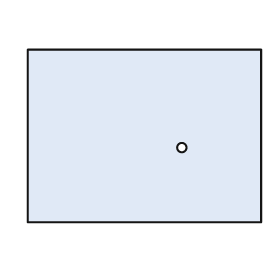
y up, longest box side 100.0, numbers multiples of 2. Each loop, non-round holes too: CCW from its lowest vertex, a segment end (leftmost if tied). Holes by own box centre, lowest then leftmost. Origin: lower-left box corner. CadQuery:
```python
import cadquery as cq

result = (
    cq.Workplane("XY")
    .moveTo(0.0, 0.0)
    .lineTo(100.0, 0.0)
    .lineTo(100.0, 74.0)
    .lineTo(0.0, 74.0)
    .close()
    .moveTo(66.0, 32.0)
    .circle(2.0)
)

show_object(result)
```